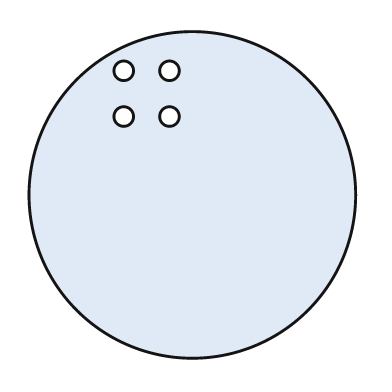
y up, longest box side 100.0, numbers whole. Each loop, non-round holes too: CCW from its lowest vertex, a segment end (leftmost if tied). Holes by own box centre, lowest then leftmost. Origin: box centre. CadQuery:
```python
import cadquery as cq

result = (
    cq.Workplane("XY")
    .moveTo(0.0, 0.0)
    .circle(50.0)
    .moveTo(-21.0, 24.0)
    .circle(3.0)
    .moveTo(-7.0, 24.0)
    .circle(3.0)
    .moveTo(-21.0, 38.0)
    .circle(3.0)
    .moveTo(-7.0, 38.0)
    .circle(3.0)
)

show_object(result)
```